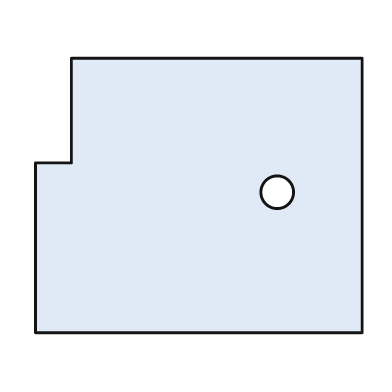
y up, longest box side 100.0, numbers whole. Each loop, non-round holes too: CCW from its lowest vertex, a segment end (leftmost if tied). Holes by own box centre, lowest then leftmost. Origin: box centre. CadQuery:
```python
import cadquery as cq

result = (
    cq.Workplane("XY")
    .moveTo(-50.0, -42.0)
    .lineTo(50.0, -42.0)
    .lineTo(50.0, 42.0)
    .lineTo(-39.0, 42.0)
    .lineTo(-39.0, 10.0)
    .lineTo(-50.0, 10.0)
    .close()
    .moveTo(24.0, 1.0)
    .circle(5.0)
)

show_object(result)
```